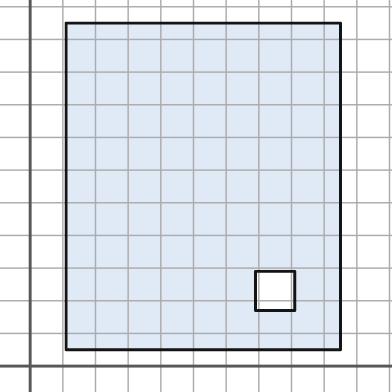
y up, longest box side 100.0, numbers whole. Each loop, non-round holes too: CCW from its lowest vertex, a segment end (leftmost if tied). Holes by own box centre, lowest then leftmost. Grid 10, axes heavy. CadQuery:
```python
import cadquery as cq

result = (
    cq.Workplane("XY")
    .moveTo(11.0, 5.0)
    .lineTo(95.0, 5.0)
    .lineTo(95.0, 105.0)
    .lineTo(11.0, 105.0)
    .close()
    .moveTo(69.0, 17.0)
    .lineTo(81.0, 17.0)
    .lineTo(81.0, 29.0)
    .lineTo(69.0, 29.0)
    .close()
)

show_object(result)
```